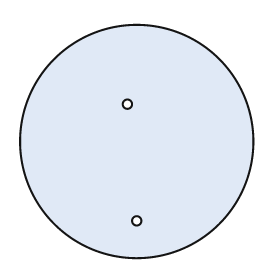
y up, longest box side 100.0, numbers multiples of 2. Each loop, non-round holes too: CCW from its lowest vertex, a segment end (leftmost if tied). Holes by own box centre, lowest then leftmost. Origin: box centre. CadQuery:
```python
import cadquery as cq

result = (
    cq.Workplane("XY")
    .moveTo(0.0, 0.0)
    .circle(50.0)
    .moveTo(0.0, -34.0)
    .circle(2.0)
    .moveTo(-4.0, 16.0)
    .circle(2.0)
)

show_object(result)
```